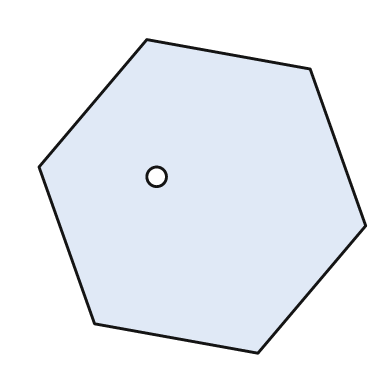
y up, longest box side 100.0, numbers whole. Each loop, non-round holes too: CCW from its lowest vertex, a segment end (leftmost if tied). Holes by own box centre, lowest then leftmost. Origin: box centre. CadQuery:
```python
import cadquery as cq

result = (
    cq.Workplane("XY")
    .moveTo(17.0, -48.0)
    .lineTo(50.0, -9.0)
    .lineTo(33.0, 39.0)
    .lineTo(-17.0, 48.0)
    .lineTo(-50.0, 9.0)
    .lineTo(-33.0, -39.0)
    .close()
    .moveTo(-14.0, 6.0)
    .circle(3.0)
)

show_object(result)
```